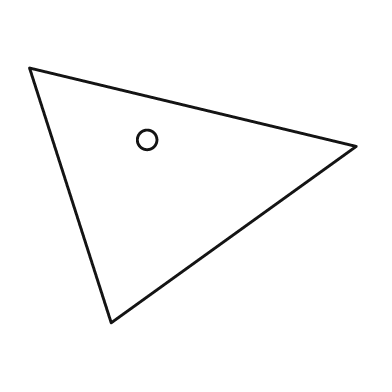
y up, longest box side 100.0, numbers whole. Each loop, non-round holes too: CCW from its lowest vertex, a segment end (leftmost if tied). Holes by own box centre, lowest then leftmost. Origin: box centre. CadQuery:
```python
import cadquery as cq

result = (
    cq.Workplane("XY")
    .moveTo(-25.0, -39.0)
    .lineTo(50.0, 15.0)
    .lineTo(-50.0, 39.0)
    .close()
    .moveTo(-14.0, 17.0)
    .circle(3.0)
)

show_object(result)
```